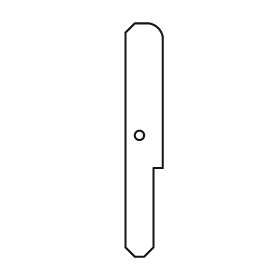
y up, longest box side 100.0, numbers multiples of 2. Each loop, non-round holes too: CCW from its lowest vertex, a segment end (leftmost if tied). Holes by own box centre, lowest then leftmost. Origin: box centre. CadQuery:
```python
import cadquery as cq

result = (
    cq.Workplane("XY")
    .moveTo(-4.0, -50.0)
    .lineTo(0.0, -50.0)
    .lineTo(4.0, -46.0)
    .lineTo(4.0, -12.0)
    .lineTo(8.0, -12.0)
    .lineTo(8.0, 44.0)
    .threePointArc((6.0, 48.0), (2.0, 50.0))
    .lineTo(-4.0, 50.0)
    .lineTo(-8.0, 46.0)
    .lineTo(-8.0, -46.0)
    .close()
    .moveTo(-2.0, 2.0)
    .circle(2.0)
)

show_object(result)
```